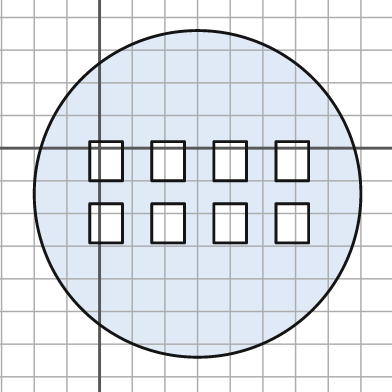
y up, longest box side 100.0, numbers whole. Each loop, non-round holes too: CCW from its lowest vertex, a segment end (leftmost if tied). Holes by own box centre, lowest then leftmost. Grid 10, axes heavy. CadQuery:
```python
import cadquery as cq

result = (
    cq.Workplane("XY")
    .moveTo(30.0, -14.0)
    .circle(50.0)
    .moveTo(-3.0, -29.0)
    .lineTo(7.0, -29.0)
    .lineTo(7.0, -17.0)
    .lineTo(-3.0, -17.0)
    .close()
    .moveTo(16.0, -29.0)
    .lineTo(26.0, -29.0)
    .lineTo(26.0, -17.0)
    .lineTo(16.0, -17.0)
    .close()
    .moveTo(35.0, -29.0)
    .lineTo(45.0, -29.0)
    .lineTo(45.0, -17.0)
    .lineTo(35.0, -17.0)
    .close()
    .moveTo(54.0, -29.0)
    .lineTo(64.0, -29.0)
    .lineTo(64.0, -17.0)
    .lineTo(54.0, -17.0)
    .close()
    .moveTo(-3.0, -10.0)
    .lineTo(7.0, -10.0)
    .lineTo(7.0, 2.0)
    .lineTo(-3.0, 2.0)
    .close()
    .moveTo(16.0, -10.0)
    .lineTo(26.0, -10.0)
    .lineTo(26.0, 2.0)
    .lineTo(16.0, 2.0)
    .close()
    .moveTo(35.0, -10.0)
    .lineTo(45.0, -10.0)
    .lineTo(45.0, 2.0)
    .lineTo(35.0, 2.0)
    .close()
    .moveTo(54.0, -10.0)
    .lineTo(64.0, -10.0)
    .lineTo(64.0, 2.0)
    .lineTo(54.0, 2.0)
    .close()
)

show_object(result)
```